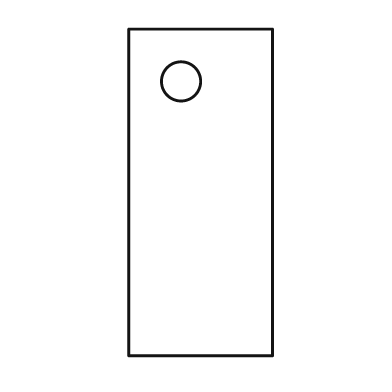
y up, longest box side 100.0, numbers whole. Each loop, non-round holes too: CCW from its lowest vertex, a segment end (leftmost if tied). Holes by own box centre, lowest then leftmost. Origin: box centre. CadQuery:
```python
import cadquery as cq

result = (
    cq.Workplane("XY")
    .moveTo(-22.0, -50.0)
    .lineTo(22.0, -50.0)
    .lineTo(22.0, 50.0)
    .lineTo(-22.0, 50.0)
    .close()
    .moveTo(-6.0, 34.0)
    .circle(6.0)
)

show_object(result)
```